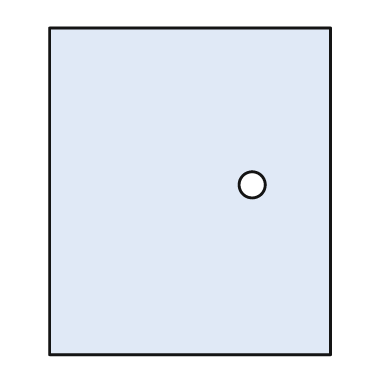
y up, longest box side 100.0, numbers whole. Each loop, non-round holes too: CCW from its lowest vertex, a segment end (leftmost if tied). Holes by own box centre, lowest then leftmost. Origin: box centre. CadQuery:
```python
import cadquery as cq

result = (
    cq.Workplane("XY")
    .moveTo(-43.0, -50.0)
    .lineTo(43.0, -50.0)
    .lineTo(43.0, 50.0)
    .lineTo(-43.0, 50.0)
    .close()
    .moveTo(19.0, 2.0)
    .circle(4.0)
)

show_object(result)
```